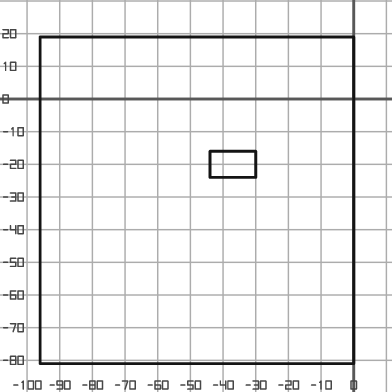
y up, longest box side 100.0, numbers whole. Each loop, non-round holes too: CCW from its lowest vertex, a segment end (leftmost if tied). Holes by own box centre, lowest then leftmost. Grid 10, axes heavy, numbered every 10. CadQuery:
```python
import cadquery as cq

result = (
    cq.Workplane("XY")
    .moveTo(-96.0, -81.0)
    .lineTo(0.0, -81.0)
    .lineTo(0.0, 19.0)
    .lineTo(-96.0, 19.0)
    .close()
    .moveTo(-44.0, -24.0)
    .lineTo(-30.0, -24.0)
    .lineTo(-30.0, -16.0)
    .lineTo(-44.0, -16.0)
    .close()
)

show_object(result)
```